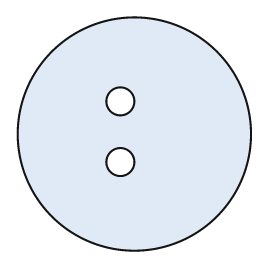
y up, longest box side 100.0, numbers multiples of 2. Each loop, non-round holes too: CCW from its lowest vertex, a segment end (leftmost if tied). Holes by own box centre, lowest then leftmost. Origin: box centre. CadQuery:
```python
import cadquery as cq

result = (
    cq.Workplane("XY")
    .moveTo(0.0, 0.0)
    .circle(50.0)
    .moveTo(-6.0, -12.0)
    .circle(6.0)
    .moveTo(-6.0, 14.0)
    .circle(6.0)
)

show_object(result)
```